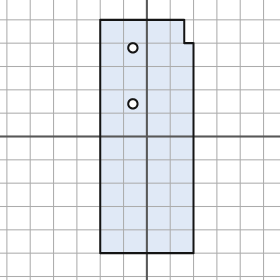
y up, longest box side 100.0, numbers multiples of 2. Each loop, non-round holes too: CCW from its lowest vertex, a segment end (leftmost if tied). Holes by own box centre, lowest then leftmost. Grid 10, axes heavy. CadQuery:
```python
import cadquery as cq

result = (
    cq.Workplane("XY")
    .moveTo(-20.0, -50.0)
    .lineTo(20.0, -50.0)
    .lineTo(20.0, 40.0)
    .lineTo(16.0, 40.0)
    .lineTo(16.0, 50.0)
    .lineTo(-20.0, 50.0)
    .close()
    .moveTo(-6.0, 14.0)
    .circle(2.0)
    .moveTo(-6.0, 38.0)
    .circle(2.0)
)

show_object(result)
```